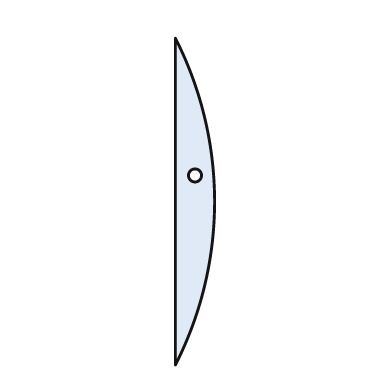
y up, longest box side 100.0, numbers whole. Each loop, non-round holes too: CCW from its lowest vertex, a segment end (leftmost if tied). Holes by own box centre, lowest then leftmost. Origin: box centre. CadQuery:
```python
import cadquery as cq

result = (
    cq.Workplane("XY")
    .moveTo(-6.0, -50.0)
    .threePointArc((6.0, 0.0), (-6.0, 50.0))
    .close()
    .moveTo(0.0, 8.0)
    .circle(2.0)
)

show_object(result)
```